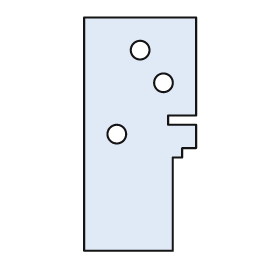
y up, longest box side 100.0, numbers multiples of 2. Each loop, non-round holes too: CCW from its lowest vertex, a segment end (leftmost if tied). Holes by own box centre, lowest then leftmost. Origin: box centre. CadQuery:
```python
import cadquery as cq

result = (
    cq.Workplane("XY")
    .moveTo(-24.0, -50.0)
    .lineTo(14.0, -50.0)
    .lineTo(14.0, -10.0)
    .lineTo(18.0, -10.0)
    .lineTo(18.0, -6.0)
    .lineTo(24.0, -6.0)
    .lineTo(24.0, 4.0)
    .lineTo(12.0, 4.0)
    .lineTo(12.0, 8.0)
    .lineTo(24.0, 8.0)
    .lineTo(24.0, 50.0)
    .lineTo(-24.0, 50.0)
    .close()
    .moveTo(-10.0, 0.0)
    .circle(4.0)
    .moveTo(10.0, 22.0)
    .circle(4.0)
    .moveTo(0.0, 36.0)
    .circle(4.0)
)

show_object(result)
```